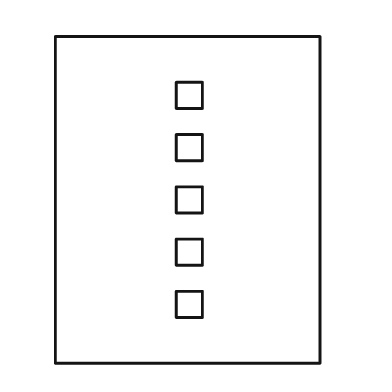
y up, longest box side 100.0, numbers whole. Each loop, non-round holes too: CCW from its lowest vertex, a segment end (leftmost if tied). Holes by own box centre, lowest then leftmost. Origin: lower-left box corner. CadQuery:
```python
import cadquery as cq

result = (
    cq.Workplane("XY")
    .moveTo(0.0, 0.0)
    .lineTo(81.0, 0.0)
    .lineTo(81.0, 100.0)
    .lineTo(0.0, 100.0)
    .close()
    .moveTo(37.0, 14.0)
    .lineTo(45.0, 14.0)
    .lineTo(45.0, 22.0)
    .lineTo(37.0, 22.0)
    .close()
    .moveTo(37.0, 30.0)
    .lineTo(45.0, 30.0)
    .lineTo(45.0, 38.0)
    .lineTo(37.0, 38.0)
    .close()
    .moveTo(37.0, 46.0)
    .lineTo(45.0, 46.0)
    .lineTo(45.0, 54.0)
    .lineTo(37.0, 54.0)
    .close()
    .moveTo(37.0, 62.0)
    .lineTo(45.0, 62.0)
    .lineTo(45.0, 70.0)
    .lineTo(37.0, 70.0)
    .close()
    .moveTo(37.0, 78.0)
    .lineTo(45.0, 78.0)
    .lineTo(45.0, 86.0)
    .lineTo(37.0, 86.0)
    .close()
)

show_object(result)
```